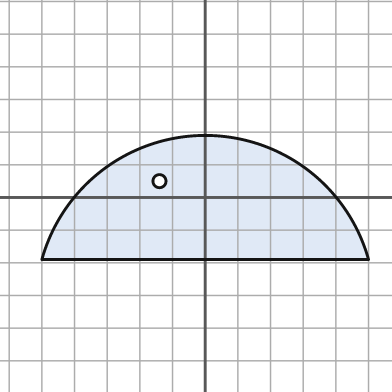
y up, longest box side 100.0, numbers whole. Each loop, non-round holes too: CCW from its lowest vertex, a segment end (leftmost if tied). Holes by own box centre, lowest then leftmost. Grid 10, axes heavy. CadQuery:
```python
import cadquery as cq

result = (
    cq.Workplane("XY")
    .moveTo(-50.0, -19.0)
    .lineTo(50.0, -19.0)
    .threePointArc((0.0, 19.0), (-50.0, -19.0))
    .close()
    .moveTo(-14.0, 5.0)
    .circle(2.0)
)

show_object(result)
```